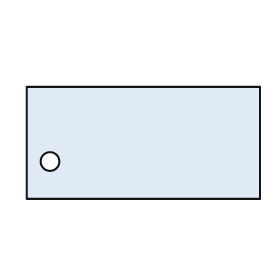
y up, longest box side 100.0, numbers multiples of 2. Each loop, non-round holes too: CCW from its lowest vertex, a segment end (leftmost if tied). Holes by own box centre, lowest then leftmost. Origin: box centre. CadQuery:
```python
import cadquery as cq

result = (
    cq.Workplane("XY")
    .moveTo(-50.0, -24.0)
    .lineTo(50.0, -24.0)
    .lineTo(50.0, 24.0)
    .lineTo(-50.0, 24.0)
    .close()
    .moveTo(-40.0, -8.0)
    .circle(4.0)
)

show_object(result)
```